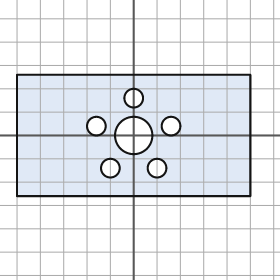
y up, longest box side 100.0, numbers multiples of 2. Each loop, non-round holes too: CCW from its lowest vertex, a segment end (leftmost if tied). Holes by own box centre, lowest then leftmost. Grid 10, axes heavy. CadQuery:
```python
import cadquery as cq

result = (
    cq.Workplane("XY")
    .moveTo(-50.0, -26.0)
    .lineTo(50.0, -26.0)
    .lineTo(50.0, 26.0)
    .lineTo(-50.0, 26.0)
    .close()
    .moveTo(-10.0, -14.0)
    .circle(4.0)
    .moveTo(10.0, -14.0)
    .circle(4.0)
    .moveTo(0.0, 0.0)
    .circle(8.0)
    .moveTo(-16.0, 4.0)
    .circle(4.0)
    .moveTo(16.0, 4.0)
    .circle(4.0)
    .moveTo(0.0, 16.0)
    .circle(4.0)
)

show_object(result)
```